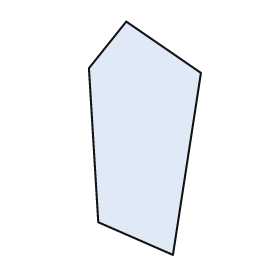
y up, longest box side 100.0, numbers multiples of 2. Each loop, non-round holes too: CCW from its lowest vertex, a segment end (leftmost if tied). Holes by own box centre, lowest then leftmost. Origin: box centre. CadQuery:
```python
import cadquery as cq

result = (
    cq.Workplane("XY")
    .moveTo(12.0, -50.0)
    .lineTo(24.0, 28.0)
    .lineTo(-8.0, 50.0)
    .lineTo(-24.0, 30.0)
    .lineTo(-20.0, -36.0)
    .close()
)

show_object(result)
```